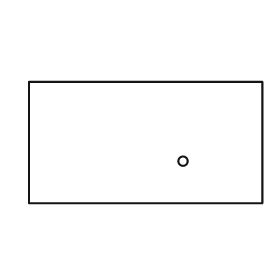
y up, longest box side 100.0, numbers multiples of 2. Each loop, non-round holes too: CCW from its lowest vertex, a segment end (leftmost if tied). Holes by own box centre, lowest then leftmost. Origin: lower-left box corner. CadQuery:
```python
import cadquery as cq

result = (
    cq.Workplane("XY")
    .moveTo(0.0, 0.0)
    .lineTo(100.0, 0.0)
    .lineTo(100.0, 52.0)
    .lineTo(0.0, 52.0)
    .close()
    .moveTo(66.0, 18.0)
    .circle(2.0)
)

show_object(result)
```